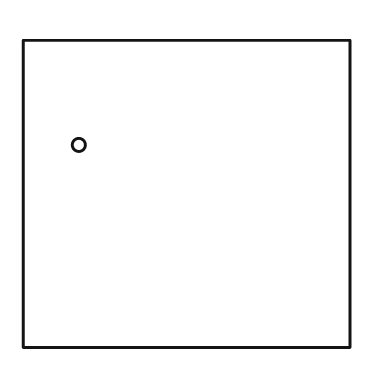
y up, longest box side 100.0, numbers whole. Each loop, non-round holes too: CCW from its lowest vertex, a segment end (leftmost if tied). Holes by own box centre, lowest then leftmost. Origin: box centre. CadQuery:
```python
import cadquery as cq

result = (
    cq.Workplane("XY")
    .moveTo(-50.0, -47.0)
    .lineTo(50.0, -47.0)
    .lineTo(50.0, 47.0)
    .lineTo(-50.0, 47.0)
    .close()
    .moveTo(-33.0, 15.0)
    .circle(2.0)
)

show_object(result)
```